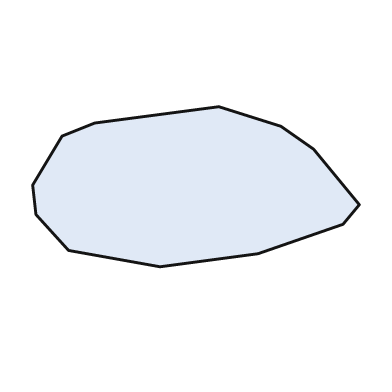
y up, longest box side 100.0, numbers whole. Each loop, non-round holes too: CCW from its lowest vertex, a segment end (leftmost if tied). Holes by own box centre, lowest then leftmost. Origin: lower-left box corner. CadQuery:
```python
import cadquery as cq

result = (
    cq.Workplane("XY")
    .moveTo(39.0, 0.0)
    .lineTo(69.0, 4.0)
    .lineTo(95.0, 13.0)
    .lineTo(100.0, 19.0)
    .lineTo(86.0, 36.0)
    .lineTo(76.0, 43.0)
    .lineTo(57.0, 49.0)
    .lineTo(19.0, 44.0)
    .lineTo(9.0, 40.0)
    .lineTo(0.0, 25.0)
    .lineTo(1.0, 16.0)
    .lineTo(11.0, 5.0)
    .close()
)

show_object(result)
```